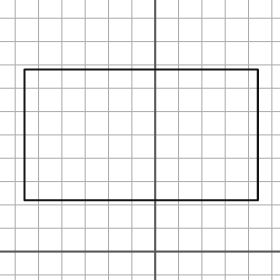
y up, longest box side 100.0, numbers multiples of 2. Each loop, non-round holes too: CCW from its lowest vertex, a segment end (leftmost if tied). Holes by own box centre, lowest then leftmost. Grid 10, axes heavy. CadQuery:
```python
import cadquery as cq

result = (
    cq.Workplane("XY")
    .moveTo(-56.0, 22.0)
    .lineTo(44.0, 22.0)
    .lineTo(44.0, 78.0)
    .lineTo(-56.0, 78.0)
    .close()
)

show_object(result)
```